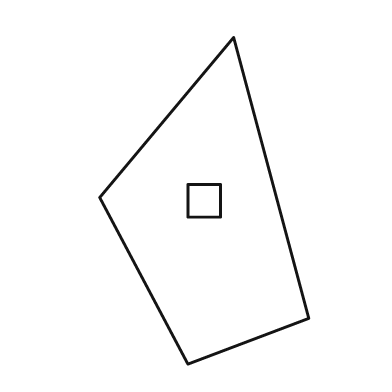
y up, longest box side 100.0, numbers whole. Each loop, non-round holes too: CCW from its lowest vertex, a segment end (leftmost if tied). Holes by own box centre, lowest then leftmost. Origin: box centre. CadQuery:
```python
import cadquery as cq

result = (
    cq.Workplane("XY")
    .moveTo(-5.0, -50.0)
    .lineTo(32.0, -36.0)
    .lineTo(9.0, 50.0)
    .lineTo(-32.0, 1.0)
    .close()
    .moveTo(-5.0, -5.0)
    .lineTo(5.0, -5.0)
    .lineTo(5.0, 5.0)
    .lineTo(-5.0, 5.0)
    .close()
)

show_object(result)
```